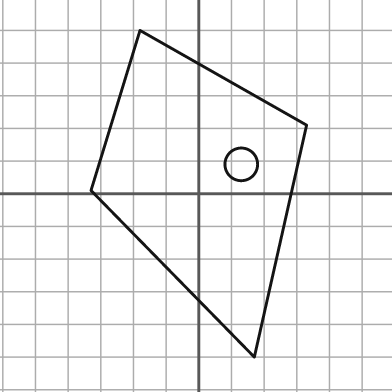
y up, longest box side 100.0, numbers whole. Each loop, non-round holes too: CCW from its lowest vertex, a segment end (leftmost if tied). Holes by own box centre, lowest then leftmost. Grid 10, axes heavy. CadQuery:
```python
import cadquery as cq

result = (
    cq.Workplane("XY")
    .moveTo(17.0, -50.0)
    .lineTo(33.0, 21.0)
    .lineTo(-18.0, 50.0)
    .lineTo(-33.0, 1.0)
    .close()
    .moveTo(13.0, 9.0)
    .circle(5.0)
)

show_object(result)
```